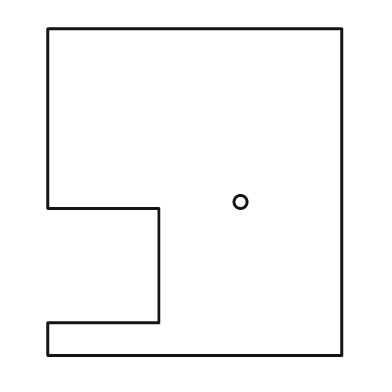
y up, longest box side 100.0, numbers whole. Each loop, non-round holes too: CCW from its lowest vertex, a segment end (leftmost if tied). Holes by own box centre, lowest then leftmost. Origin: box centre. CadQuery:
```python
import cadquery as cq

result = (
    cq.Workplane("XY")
    .moveTo(-45.0, -50.0)
    .lineTo(45.0, -50.0)
    .lineTo(45.0, 50.0)
    .lineTo(-45.0, 50.0)
    .lineTo(-45.0, -5.0)
    .lineTo(-11.0, -5.0)
    .lineTo(-11.0, -40.0)
    .lineTo(-45.0, -40.0)
    .close()
    .moveTo(14.0, -3.0)
    .circle(2.0)
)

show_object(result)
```